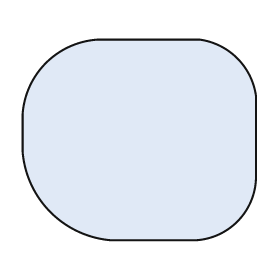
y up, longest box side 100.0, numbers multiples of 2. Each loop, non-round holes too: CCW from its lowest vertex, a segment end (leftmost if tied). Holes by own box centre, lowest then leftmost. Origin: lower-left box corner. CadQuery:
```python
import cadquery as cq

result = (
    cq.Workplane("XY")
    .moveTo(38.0, 0.0)
    .lineTo(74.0, 0.0)
    .threePointArc((92.0, 8.0), (100.0, 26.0))
    .lineTo(100.0, 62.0)
    .threePointArc((92.0, 78.0), (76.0, 86.0))
    .lineTo(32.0, 86.0)
    .threePointArc((10.0, 76.0), (0.0, 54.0))
    .lineTo(0.0, 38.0)
    .threePointArc((12.0, 12.0), (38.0, 0.0))
    .close()
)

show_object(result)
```